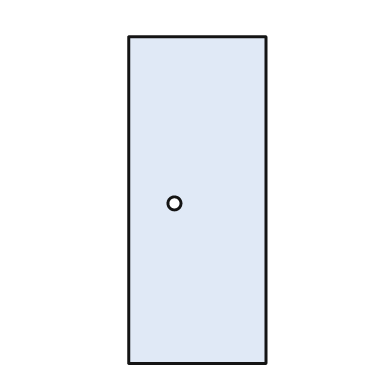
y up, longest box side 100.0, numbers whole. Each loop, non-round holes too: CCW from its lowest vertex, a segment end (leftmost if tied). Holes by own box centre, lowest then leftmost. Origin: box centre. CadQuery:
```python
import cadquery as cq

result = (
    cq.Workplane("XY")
    .moveTo(-21.0, -50.0)
    .lineTo(21.0, -50.0)
    .lineTo(21.0, 50.0)
    .lineTo(-21.0, 50.0)
    .close()
    .moveTo(-7.0, -1.0)
    .circle(2.0)
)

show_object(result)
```